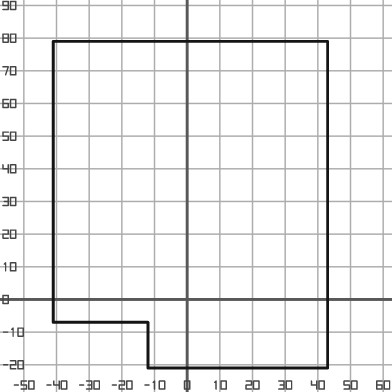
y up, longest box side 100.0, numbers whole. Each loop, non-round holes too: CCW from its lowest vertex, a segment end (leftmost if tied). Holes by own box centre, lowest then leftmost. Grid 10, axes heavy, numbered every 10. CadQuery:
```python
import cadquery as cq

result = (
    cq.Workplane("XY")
    .moveTo(-12.0, -21.0)
    .lineTo(43.0, -21.0)
    .lineTo(43.0, 79.0)
    .lineTo(-41.0, 79.0)
    .lineTo(-41.0, -7.0)
    .lineTo(-12.0, -7.0)
    .close()
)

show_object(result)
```